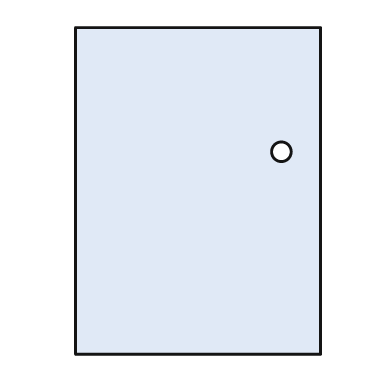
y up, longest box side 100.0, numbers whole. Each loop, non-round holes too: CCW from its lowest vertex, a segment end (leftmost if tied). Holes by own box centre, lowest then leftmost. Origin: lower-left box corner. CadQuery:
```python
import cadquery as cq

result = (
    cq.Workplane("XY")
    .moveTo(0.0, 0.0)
    .lineTo(75.0, 0.0)
    .lineTo(75.0, 100.0)
    .lineTo(0.0, 100.0)
    .close()
    .moveTo(63.0, 62.0)
    .circle(3.0)
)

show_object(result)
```